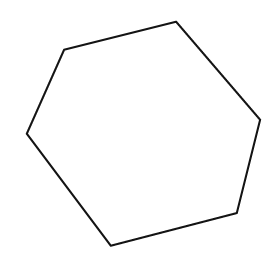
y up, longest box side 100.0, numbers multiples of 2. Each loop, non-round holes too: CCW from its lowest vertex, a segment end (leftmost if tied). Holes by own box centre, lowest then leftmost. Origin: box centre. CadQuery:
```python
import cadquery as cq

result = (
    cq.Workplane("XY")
    .moveTo(-14.0, -48.0)
    .lineTo(40.0, -34.0)
    .lineTo(50.0, 6.0)
    .lineTo(14.0, 48.0)
    .lineTo(-34.0, 36.0)
    .lineTo(-50.0, 0.0)
    .close()
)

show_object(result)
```